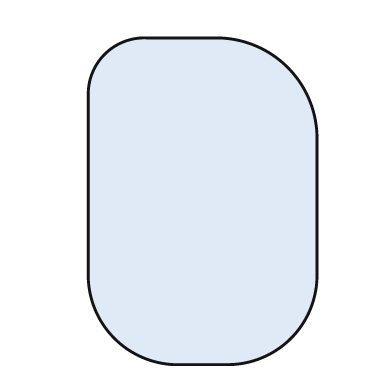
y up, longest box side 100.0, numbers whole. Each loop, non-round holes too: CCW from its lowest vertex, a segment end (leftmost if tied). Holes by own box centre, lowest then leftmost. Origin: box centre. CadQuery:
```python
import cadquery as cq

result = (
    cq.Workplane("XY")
    .moveTo(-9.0, -50.0)
    .lineTo(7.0, -50.0)
    .threePointArc((27.0, -42.0), (35.0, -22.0))
    .lineTo(35.0, 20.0)
    .threePointArc((26.0, 41.0), (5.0, 50.0))
    .lineTo(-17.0, 50.0)
    .threePointArc((-30.0, 45.0), (-35.0, 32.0))
    .lineTo(-35.0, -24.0)
    .threePointArc((-27.0, -42.0), (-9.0, -50.0))
    .close()
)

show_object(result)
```